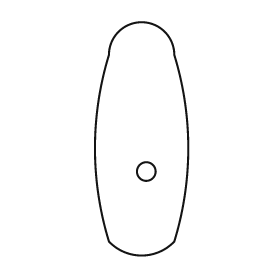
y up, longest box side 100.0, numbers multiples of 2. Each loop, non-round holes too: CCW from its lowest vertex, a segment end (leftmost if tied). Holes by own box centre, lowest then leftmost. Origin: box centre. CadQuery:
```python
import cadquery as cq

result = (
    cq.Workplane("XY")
    .moveTo(-14.0, -44.0)
    .threePointArc((0.0, -50.0), (14.0, -44.0))
    .threePointArc((20.0, -4.0), (14.0, 36.0))
    .threePointArc((0.0, 50.0), (-14.0, 36.0))
    .threePointArc((-20.0, -4.0), (-14.0, -44.0))
    .close()
    .moveTo(2.0, -14.0)
    .circle(4.0)
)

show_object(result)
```